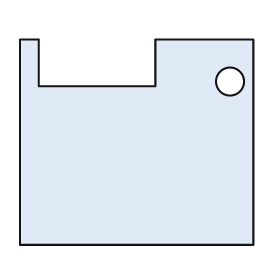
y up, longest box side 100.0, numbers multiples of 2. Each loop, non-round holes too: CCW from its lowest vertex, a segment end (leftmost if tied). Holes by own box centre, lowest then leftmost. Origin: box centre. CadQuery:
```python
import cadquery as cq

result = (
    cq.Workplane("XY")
    .moveTo(-50.0, -44.0)
    .lineTo(50.0, -44.0)
    .lineTo(50.0, 44.0)
    .lineTo(8.0, 44.0)
    .lineTo(8.0, 24.0)
    .lineTo(-42.0, 24.0)
    .lineTo(-42.0, 44.0)
    .lineTo(-50.0, 44.0)
    .close()
    .moveTo(40.0, 26.0)
    .circle(6.0)
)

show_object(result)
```